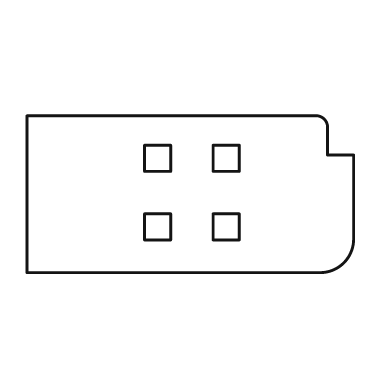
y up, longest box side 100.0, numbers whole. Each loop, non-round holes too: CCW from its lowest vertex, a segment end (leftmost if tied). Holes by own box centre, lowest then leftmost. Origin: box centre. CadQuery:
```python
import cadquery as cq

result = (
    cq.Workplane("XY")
    .moveTo(-50.0, -24.0)
    .lineTo(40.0, -24.0)
    .threePointArc((47.0, -21.0), (50.0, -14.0))
    .lineTo(50.0, 12.0)
    .lineTo(42.0, 12.0)
    .lineTo(42.0, 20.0)
    .threePointArc((41.0, 23.0), (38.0, 24.0))
    .lineTo(-50.0, 24.0)
    .close()
    .moveTo(-14.0, -14.0)
    .lineTo(-6.0, -14.0)
    .lineTo(-6.0, -6.0)
    .lineTo(-14.0, -6.0)
    .close()
    .moveTo(7.0, -14.0)
    .lineTo(15.0, -14.0)
    .lineTo(15.0, -6.0)
    .lineTo(7.0, -6.0)
    .close()
    .moveTo(-14.0, 7.0)
    .lineTo(-6.0, 7.0)
    .lineTo(-6.0, 15.0)
    .lineTo(-14.0, 15.0)
    .close()
    .moveTo(7.0, 7.0)
    .lineTo(15.0, 7.0)
    .lineTo(15.0, 15.0)
    .lineTo(7.0, 15.0)
    .close()
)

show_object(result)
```